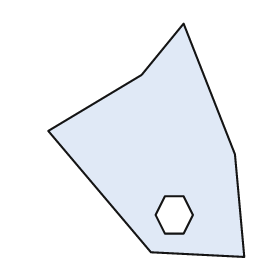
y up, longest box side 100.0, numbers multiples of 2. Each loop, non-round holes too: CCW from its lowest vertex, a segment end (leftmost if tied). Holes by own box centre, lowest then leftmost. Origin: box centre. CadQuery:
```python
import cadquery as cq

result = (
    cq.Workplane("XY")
    .moveTo(42.0, -50.0)
    .lineTo(38.0, -6.0)
    .lineTo(16.0, 50.0)
    .lineTo(-2.0, 28.0)
    .lineTo(-42.0, 4.0)
    .lineTo(2.0, -48.0)
    .close()
    .moveTo(8.0, -40.0)
    .lineTo(16.0, -40.0)
    .lineTo(20.0, -32.0)
    .lineTo(16.0, -24.0)
    .lineTo(8.0, -24.0)
    .lineTo(4.0, -32.0)
    .close()
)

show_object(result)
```